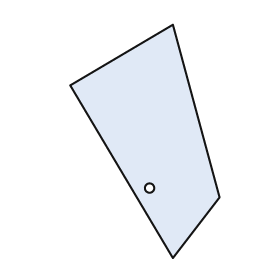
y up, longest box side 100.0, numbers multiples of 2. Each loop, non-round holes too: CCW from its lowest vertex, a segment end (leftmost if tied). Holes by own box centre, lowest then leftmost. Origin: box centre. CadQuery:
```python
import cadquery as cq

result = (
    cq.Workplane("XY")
    .moveTo(12.0, -50.0)
    .lineTo(32.0, -24.0)
    .lineTo(12.0, 50.0)
    .lineTo(-32.0, 24.0)
    .close()
    .moveTo(2.0, -20.0)
    .circle(2.0)
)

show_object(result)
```